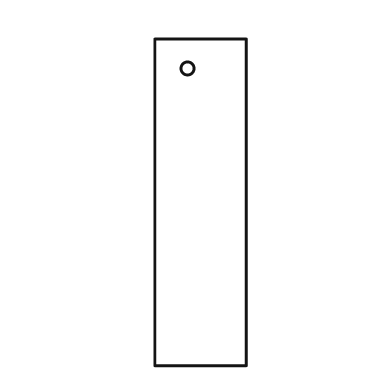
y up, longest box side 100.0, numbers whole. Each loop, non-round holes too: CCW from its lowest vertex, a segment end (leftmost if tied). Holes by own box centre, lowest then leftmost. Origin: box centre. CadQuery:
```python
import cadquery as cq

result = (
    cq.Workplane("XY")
    .moveTo(-14.0, -50.0)
    .lineTo(14.0, -50.0)
    .lineTo(14.0, 50.0)
    .lineTo(-14.0, 50.0)
    .close()
    .moveTo(-4.0, 41.0)
    .circle(2.0)
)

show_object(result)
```